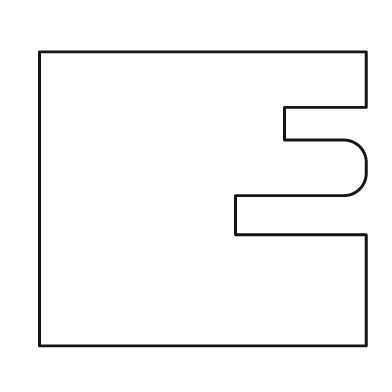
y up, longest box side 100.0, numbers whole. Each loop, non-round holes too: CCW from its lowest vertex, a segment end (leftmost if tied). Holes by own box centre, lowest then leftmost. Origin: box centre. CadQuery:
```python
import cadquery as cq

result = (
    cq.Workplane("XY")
    .moveTo(-50.0, -45.0)
    .lineTo(50.0, -45.0)
    .lineTo(50.0, -11.0)
    .lineTo(10.0, -11.0)
    .lineTo(10.0, 1.0)
    .lineTo(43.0, 1.0)
    .threePointArc((48.0, 3.0), (50.0, 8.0))
    .lineTo(50.0, 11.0)
    .threePointArc((48.0, 16.0), (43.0, 18.0))
    .lineTo(25.0, 18.0)
    .lineTo(25.0, 28.0)
    .lineTo(50.0, 28.0)
    .lineTo(50.0, 45.0)
    .lineTo(-50.0, 45.0)
    .close()
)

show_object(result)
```